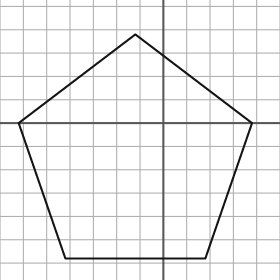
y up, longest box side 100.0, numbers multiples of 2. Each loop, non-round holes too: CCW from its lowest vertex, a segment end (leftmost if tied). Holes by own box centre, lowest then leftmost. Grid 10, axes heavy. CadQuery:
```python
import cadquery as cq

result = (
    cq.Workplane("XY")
    .moveTo(-42.0, -58.0)
    .lineTo(18.0, -58.0)
    .lineTo(38.0, 0.0)
    .lineTo(-12.0, 38.0)
    .lineTo(-62.0, 0.0)
    .close()
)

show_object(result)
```